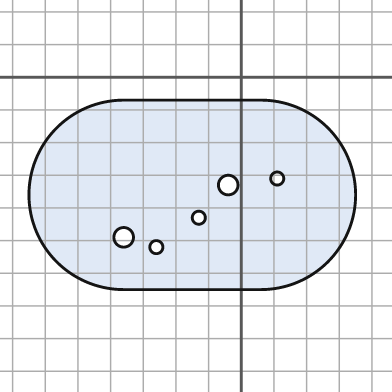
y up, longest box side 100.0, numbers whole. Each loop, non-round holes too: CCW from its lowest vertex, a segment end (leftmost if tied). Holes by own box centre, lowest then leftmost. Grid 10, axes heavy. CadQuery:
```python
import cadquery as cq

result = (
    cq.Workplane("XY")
    .moveTo(-36.0, -65.0)
    .lineTo(6.0, -65.0)
    .threePointArc((35.0, -36.0), (6.0, -7.0))
    .lineTo(-36.0, -7.0)
    .threePointArc((-65.0, -36.0), (-36.0, -65.0))
    .close()
    .moveTo(-26.0, -52.0)
    .circle(2.0)
    .moveTo(-36.0, -49.0)
    .circle(3.0)
    .moveTo(-13.0, -43.0)
    .circle(2.0)
    .moveTo(-4.0, -33.0)
    .circle(3.0)
    .moveTo(11.0, -31.0)
    .circle(2.0)
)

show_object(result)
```